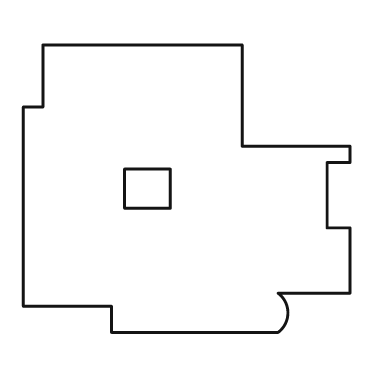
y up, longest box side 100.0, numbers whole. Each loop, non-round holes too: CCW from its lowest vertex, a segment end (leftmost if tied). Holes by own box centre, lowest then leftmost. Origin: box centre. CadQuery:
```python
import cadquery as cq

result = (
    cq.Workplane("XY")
    .moveTo(-23.0, -44.0)
    .lineTo(28.0, -44.0)
    .threePointArc((31.0, -38.0), (28.0, -32.0))
    .lineTo(50.0, -32.0)
    .lineTo(50.0, -12.0)
    .lineTo(43.0, -12.0)
    .lineTo(43.0, 8.0)
    .lineTo(50.0, 8.0)
    .lineTo(50.0, 13.0)
    .lineTo(17.0, 13.0)
    .lineTo(17.0, 44.0)
    .lineTo(-44.0, 44.0)
    .lineTo(-44.0, 25.0)
    .lineTo(-50.0, 25.0)
    .lineTo(-50.0, -36.0)
    .lineTo(-23.0, -36.0)
    .close()
    .moveTo(-19.0, -6.0)
    .lineTo(-5.0, -6.0)
    .lineTo(-5.0, 6.0)
    .lineTo(-19.0, 6.0)
    .close()
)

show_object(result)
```